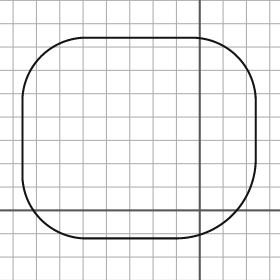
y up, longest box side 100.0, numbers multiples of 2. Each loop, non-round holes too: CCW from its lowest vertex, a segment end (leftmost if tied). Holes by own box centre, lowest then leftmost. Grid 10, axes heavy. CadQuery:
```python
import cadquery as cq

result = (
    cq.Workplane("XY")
    .moveTo(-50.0, -12.0)
    .lineTo(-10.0, -12.0)
    .threePointArc((14.0, -2.0), (24.0, 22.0))
    .lineTo(24.0, 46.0)
    .threePointArc((16.0, 66.0), (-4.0, 74.0))
    .lineTo(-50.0, 74.0)
    .threePointArc((-68.0, 66.0), (-76.0, 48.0))
    .lineTo(-76.0, 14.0)
    .threePointArc((-68.0, -4.0), (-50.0, -12.0))
    .close()
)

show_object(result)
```